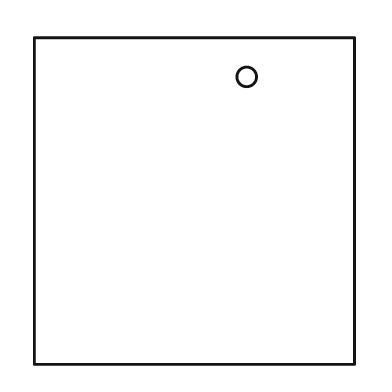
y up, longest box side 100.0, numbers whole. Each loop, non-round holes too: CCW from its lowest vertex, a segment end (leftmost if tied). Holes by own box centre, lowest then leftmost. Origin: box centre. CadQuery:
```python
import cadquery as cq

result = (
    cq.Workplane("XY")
    .moveTo(-49.0, -50.0)
    .lineTo(49.0, -50.0)
    .lineTo(49.0, 50.0)
    .lineTo(-49.0, 50.0)
    .close()
    .moveTo(16.0, 38.0)
    .circle(3.0)
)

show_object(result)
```